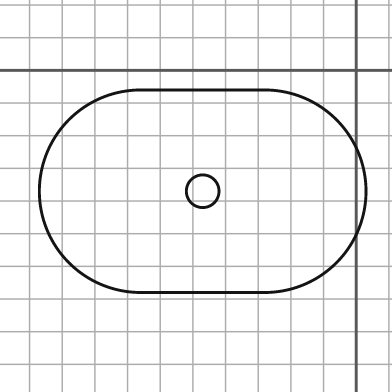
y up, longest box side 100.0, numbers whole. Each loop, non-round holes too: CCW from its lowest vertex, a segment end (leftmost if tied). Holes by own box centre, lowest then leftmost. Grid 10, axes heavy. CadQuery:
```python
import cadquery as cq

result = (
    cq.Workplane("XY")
    .moveTo(-66.0, -68.0)
    .lineTo(-28.0, -68.0)
    .threePointArc((3.0, -37.0), (-28.0, -6.0))
    .lineTo(-66.0, -6.0)
    .threePointArc((-97.0, -37.0), (-66.0, -68.0))
    .close()
    .moveTo(-47.0, -37.0)
    .circle(5.0)
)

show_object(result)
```